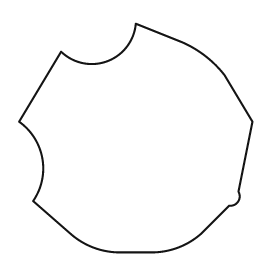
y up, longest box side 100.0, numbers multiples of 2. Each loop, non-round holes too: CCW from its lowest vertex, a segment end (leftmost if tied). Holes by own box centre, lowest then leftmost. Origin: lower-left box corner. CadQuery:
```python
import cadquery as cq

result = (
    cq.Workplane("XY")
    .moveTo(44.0, 0.0)
    .lineTo(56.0, 0.0)
    .threePointArc((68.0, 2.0), (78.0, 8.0))
    .lineTo(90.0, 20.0)
    .threePointArc((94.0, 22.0), (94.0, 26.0))
    .lineTo(100.0, 56.0)
    .lineTo(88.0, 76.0)
    .threePointArc((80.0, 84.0), (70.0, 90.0))
    .lineTo(50.0, 98.0)
    .threePointArc((38.0, 82.0), (18.0, 86.0))
    .lineTo(0.0, 56.0)
    .threePointArc((10.0, 40.0), (6.0, 22.0))
    .lineTo(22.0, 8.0)
    .threePointArc((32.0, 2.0), (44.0, 0.0))
    .close()
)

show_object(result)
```